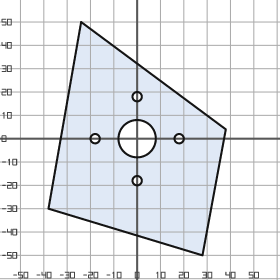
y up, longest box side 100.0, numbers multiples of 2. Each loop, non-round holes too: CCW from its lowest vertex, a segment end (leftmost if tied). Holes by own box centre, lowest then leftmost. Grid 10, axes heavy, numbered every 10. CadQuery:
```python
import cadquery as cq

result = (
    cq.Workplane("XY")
    .moveTo(28.0, -50.0)
    .lineTo(38.0, 4.0)
    .lineTo(-24.0, 50.0)
    .lineTo(-38.0, -30.0)
    .close()
    .moveTo(0.0, -18.0)
    .circle(2.0)
    .moveTo(-18.0, 0.0)
    .circle(2.0)
    .moveTo(0.0, 0.0)
    .circle(8.0)
    .moveTo(18.0, 0.0)
    .circle(2.0)
    .moveTo(0.0, 18.0)
    .circle(2.0)
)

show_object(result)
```